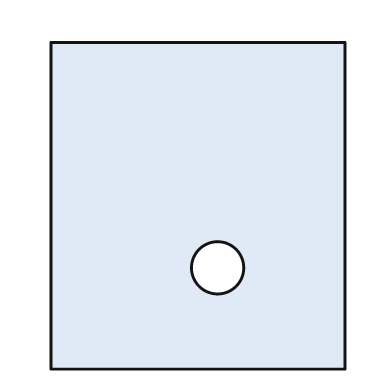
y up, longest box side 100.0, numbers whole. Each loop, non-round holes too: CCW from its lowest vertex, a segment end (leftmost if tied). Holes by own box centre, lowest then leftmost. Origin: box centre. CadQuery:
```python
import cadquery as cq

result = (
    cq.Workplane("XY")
    .moveTo(-45.0, -50.0)
    .lineTo(45.0, -50.0)
    .lineTo(45.0, 50.0)
    .lineTo(-45.0, 50.0)
    .close()
    .moveTo(6.0, -19.0)
    .circle(8.0)
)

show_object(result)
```